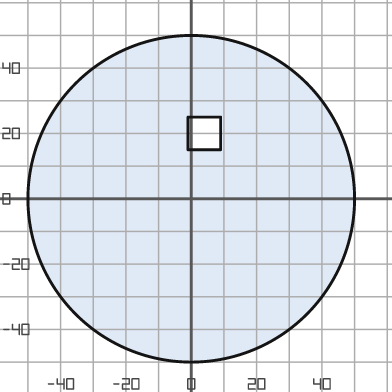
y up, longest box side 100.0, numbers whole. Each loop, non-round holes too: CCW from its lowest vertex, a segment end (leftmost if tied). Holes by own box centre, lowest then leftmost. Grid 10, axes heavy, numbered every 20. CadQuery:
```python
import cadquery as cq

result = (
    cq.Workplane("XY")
    .moveTo(0.0, 0.0)
    .circle(50.0)
    .moveTo(-1.0, 15.0)
    .lineTo(9.0, 15.0)
    .lineTo(9.0, 25.0)
    .lineTo(-1.0, 25.0)
    .close()
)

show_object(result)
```